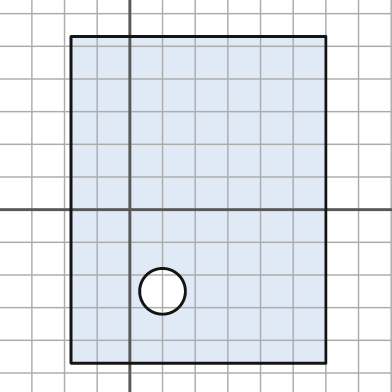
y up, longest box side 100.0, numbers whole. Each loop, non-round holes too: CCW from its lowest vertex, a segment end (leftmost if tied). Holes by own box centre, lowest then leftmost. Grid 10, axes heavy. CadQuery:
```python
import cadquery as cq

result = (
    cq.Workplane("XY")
    .moveTo(-18.0, -47.0)
    .lineTo(60.0, -47.0)
    .lineTo(60.0, 53.0)
    .lineTo(-18.0, 53.0)
    .close()
    .moveTo(10.0, -25.0)
    .circle(7.0)
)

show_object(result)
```